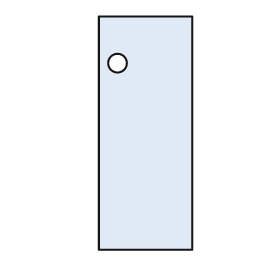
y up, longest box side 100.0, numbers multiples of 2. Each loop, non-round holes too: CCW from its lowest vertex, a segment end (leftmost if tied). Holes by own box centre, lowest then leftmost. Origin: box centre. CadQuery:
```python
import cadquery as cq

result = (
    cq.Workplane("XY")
    .moveTo(-20.0, -50.0)
    .lineTo(20.0, -50.0)
    .lineTo(20.0, 50.0)
    .lineTo(-20.0, 50.0)
    .close()
    .moveTo(-12.0, 30.0)
    .circle(4.0)
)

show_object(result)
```